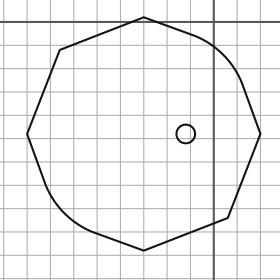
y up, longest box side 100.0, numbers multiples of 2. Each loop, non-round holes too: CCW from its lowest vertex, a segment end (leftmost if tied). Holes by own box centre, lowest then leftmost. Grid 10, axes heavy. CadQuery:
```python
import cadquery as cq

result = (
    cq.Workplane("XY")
    .moveTo(-30.0, -98.0)
    .lineTo(6.0, -84.0)
    .lineTo(20.0, -48.0)
    .lineTo(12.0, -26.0)
    .threePointArc((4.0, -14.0), (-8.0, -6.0))
    .lineTo(-30.0, 2.0)
    .lineTo(-66.0, -12.0)
    .lineTo(-80.0, -48.0)
    .lineTo(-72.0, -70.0)
    .threePointArc((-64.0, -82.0), (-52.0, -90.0))
    .close()
    .moveTo(-12.0, -48.0)
    .circle(4.0)
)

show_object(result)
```